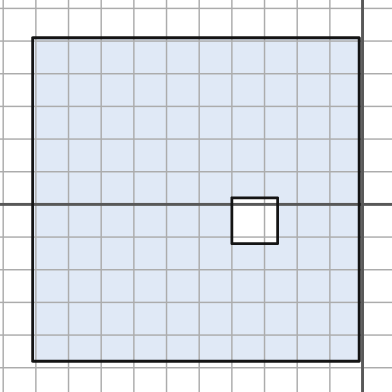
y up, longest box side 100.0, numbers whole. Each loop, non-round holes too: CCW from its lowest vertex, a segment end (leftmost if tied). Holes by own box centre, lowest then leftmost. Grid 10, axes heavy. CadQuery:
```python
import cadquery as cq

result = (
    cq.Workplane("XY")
    .moveTo(-101.0, -48.0)
    .lineTo(-1.0, -48.0)
    .lineTo(-1.0, 51.0)
    .lineTo(-101.0, 51.0)
    .close()
    .moveTo(-40.0, -12.0)
    .lineTo(-26.0, -12.0)
    .lineTo(-26.0, 2.0)
    .lineTo(-40.0, 2.0)
    .close()
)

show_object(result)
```